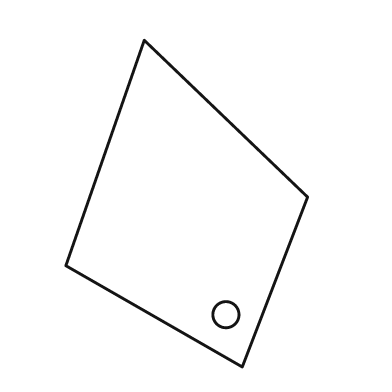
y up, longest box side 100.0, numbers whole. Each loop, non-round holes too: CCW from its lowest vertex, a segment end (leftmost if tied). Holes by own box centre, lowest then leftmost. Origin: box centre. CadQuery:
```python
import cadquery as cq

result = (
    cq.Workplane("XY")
    .moveTo(17.0, -50.0)
    .lineTo(37.0, 2.0)
    .lineTo(-13.0, 50.0)
    .lineTo(-37.0, -19.0)
    .close()
    .moveTo(12.0, -34.0)
    .circle(4.0)
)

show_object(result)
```